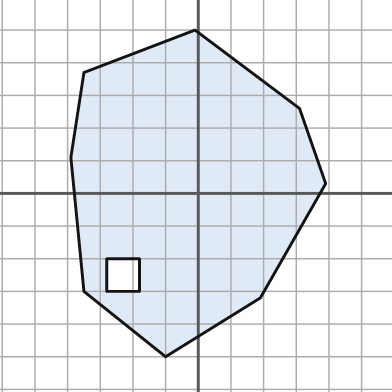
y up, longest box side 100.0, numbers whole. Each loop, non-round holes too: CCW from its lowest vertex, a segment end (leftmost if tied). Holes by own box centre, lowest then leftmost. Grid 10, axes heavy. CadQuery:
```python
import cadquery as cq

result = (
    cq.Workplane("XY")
    .moveTo(-10.0, -50.0)
    .lineTo(19.0, -32.0)
    .lineTo(39.0, 3.0)
    .lineTo(31.0, 26.0)
    .lineTo(-1.0, 50.0)
    .lineTo(-35.0, 37.0)
    .lineTo(-39.0, 11.0)
    .lineTo(-35.0, -30.0)
    .close()
    .moveTo(-28.0, -30.0)
    .lineTo(-18.0, -30.0)
    .lineTo(-18.0, -20.0)
    .lineTo(-28.0, -20.0)
    .close()
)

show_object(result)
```